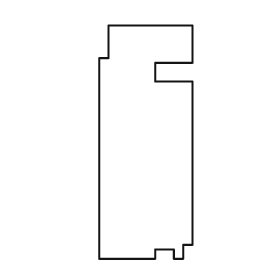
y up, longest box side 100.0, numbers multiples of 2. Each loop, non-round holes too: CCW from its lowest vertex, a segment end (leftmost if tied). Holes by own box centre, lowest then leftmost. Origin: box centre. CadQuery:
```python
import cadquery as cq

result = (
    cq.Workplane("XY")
    .moveTo(-20.0, -50.0)
    .lineTo(4.0, -50.0)
    .lineTo(4.0, -46.0)
    .lineTo(12.0, -46.0)
    .lineTo(12.0, -50.0)
    .lineTo(16.0, -50.0)
    .lineTo(16.0, -44.0)
    .lineTo(20.0, -44.0)
    .lineTo(20.0, 26.0)
    .lineTo(4.0, 26.0)
    .lineTo(4.0, 34.0)
    .lineTo(20.0, 34.0)
    .lineTo(20.0, 50.0)
    .lineTo(-16.0, 50.0)
    .lineTo(-16.0, 36.0)
    .lineTo(-20.0, 36.0)
    .close()
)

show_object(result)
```